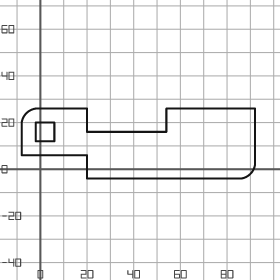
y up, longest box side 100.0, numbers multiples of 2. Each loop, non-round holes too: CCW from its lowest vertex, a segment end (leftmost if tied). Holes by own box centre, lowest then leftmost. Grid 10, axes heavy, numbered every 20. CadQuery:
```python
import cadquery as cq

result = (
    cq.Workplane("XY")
    .moveTo(20.0, -4.0)
    .lineTo(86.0, -4.0)
    .threePointArc((90.0, -2.0), (92.0, 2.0))
    .lineTo(92.0, 26.0)
    .lineTo(54.0, 26.0)
    .lineTo(54.0, 16.0)
    .lineTo(20.0, 16.0)
    .lineTo(20.0, 26.0)
    .lineTo(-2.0, 26.0)
    .threePointArc((-6.0, 24.0), (-8.0, 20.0))
    .lineTo(-8.0, 6.0)
    .lineTo(20.0, 6.0)
    .close()
    .moveTo(-2.0, 12.0)
    .lineTo(6.0, 12.0)
    .lineTo(6.0, 20.0)
    .lineTo(-2.0, 20.0)
    .close()
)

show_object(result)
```